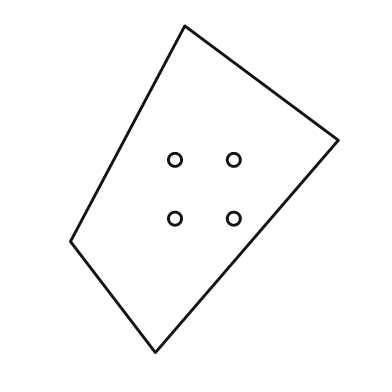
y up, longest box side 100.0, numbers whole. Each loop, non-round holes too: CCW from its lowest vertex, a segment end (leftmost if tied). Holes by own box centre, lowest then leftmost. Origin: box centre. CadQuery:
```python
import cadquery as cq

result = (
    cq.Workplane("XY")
    .moveTo(-15.0, -50.0)
    .lineTo(41.0, 15.0)
    .lineTo(-6.0, 50.0)
    .lineTo(-41.0, -16.0)
    .close()
    .moveTo(-9.0, -9.0)
    .circle(2.0)
    .moveTo(9.0, -9.0)
    .circle(2.0)
    .moveTo(-9.0, 9.0)
    .circle(2.0)
    .moveTo(9.0, 9.0)
    .circle(2.0)
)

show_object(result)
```